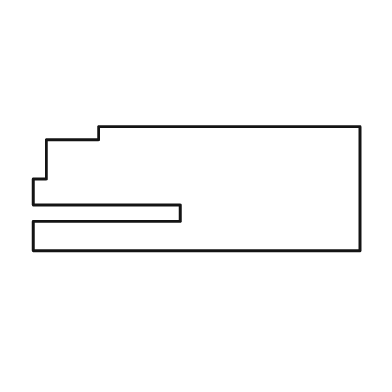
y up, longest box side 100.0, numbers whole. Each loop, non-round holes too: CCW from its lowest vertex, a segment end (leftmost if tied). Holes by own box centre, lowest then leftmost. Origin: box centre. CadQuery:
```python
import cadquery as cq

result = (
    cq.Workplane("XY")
    .moveTo(-50.0, -19.0)
    .lineTo(50.0, -19.0)
    .lineTo(50.0, 19.0)
    .lineTo(-30.0, 19.0)
    .lineTo(-30.0, 15.0)
    .lineTo(-46.0, 15.0)
    .lineTo(-46.0, 3.0)
    .lineTo(-50.0, 3.0)
    .lineTo(-50.0, -5.0)
    .lineTo(-5.0, -5.0)
    .lineTo(-5.0, -10.0)
    .lineTo(-50.0, -10.0)
    .close()
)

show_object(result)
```